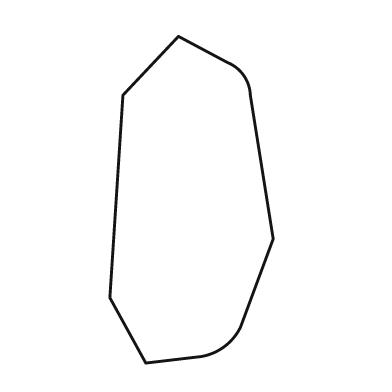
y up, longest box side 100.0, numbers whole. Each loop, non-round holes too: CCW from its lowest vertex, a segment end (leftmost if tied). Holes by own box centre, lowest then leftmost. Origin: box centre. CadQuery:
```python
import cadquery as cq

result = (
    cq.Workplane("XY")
    .moveTo(-14.0, -50.0)
    .lineTo(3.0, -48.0)
    .threePointArc((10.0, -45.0), (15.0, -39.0))
    .lineTo(25.0, -12.0)
    .lineTo(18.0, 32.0)
    .threePointArc((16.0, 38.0), (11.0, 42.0))
    .lineTo(-4.0, 50.0)
    .lineTo(-21.0, 32.0)
    .lineTo(-25.0, -30.0)
    .close()
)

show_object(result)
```